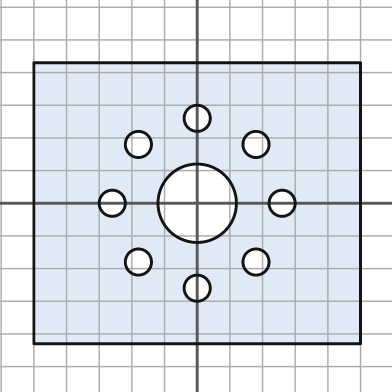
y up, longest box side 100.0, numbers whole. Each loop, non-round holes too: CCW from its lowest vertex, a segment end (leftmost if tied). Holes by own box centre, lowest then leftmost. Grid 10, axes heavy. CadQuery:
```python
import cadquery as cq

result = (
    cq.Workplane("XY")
    .moveTo(-50.0, -43.0)
    .lineTo(50.0, -43.0)
    .lineTo(50.0, 43.0)
    .lineTo(-50.0, 43.0)
    .close()
    .moveTo(0.0, -26.0)
    .circle(4.0)
    .moveTo(-18.0, -18.0)
    .circle(4.0)
    .moveTo(18.0, -18.0)
    .circle(4.0)
    .moveTo(-26.0, 0.0)
    .circle(4.0)
    .moveTo(0.0, 0.0)
    .circle(12.0)
    .moveTo(26.0, 0.0)
    .circle(4.0)
    .moveTo(-18.0, 18.0)
    .circle(4.0)
    .moveTo(18.0, 18.0)
    .circle(4.0)
    .moveTo(0.0, 26.0)
    .circle(4.0)
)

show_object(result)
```